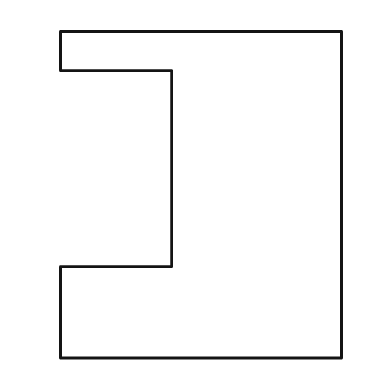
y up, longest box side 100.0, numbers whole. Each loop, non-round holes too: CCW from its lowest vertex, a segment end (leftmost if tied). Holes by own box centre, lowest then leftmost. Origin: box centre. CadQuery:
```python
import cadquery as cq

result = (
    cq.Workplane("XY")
    .moveTo(-43.0, -50.0)
    .lineTo(43.0, -50.0)
    .lineTo(43.0, 50.0)
    .lineTo(-43.0, 50.0)
    .lineTo(-43.0, 38.0)
    .lineTo(-9.0, 38.0)
    .lineTo(-9.0, -22.0)
    .lineTo(-43.0, -22.0)
    .close()
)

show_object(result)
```